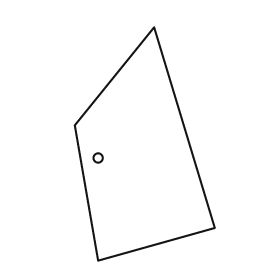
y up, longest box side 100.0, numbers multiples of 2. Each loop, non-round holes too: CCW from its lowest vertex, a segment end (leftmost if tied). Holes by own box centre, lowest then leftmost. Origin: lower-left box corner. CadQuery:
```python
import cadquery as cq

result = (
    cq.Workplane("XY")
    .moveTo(10.0, 0.0)
    .lineTo(60.0, 14.0)
    .lineTo(34.0, 100.0)
    .lineTo(0.0, 58.0)
    .close()
    .moveTo(10.0, 44.0)
    .circle(2.0)
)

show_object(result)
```